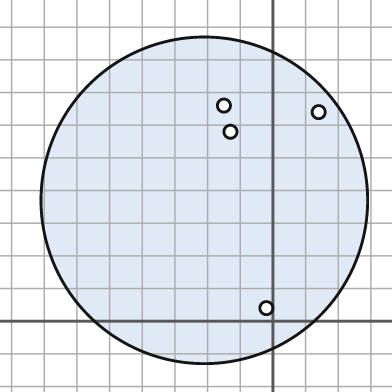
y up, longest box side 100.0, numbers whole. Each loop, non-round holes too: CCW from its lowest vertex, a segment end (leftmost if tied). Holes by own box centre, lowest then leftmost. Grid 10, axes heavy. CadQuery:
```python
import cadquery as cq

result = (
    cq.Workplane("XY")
    .moveTo(-21.0, 37.0)
    .circle(50.0)
    .moveTo(-2.0, 4.0)
    .circle(2.0)
    .moveTo(-13.0, 58.0)
    .circle(2.0)
    .moveTo(14.0, 64.0)
    .circle(2.0)
    .moveTo(-15.0, 66.0)
    .circle(2.0)
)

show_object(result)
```